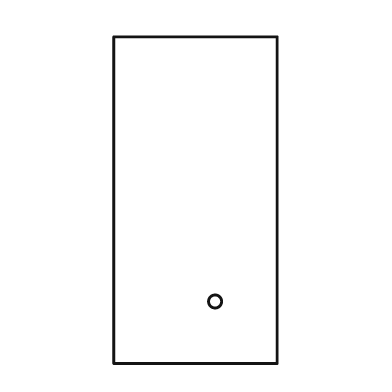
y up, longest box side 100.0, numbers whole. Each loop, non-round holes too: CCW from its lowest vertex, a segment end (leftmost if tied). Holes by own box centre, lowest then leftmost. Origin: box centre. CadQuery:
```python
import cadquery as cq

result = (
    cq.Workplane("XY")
    .moveTo(-25.0, -50.0)
    .lineTo(25.0, -50.0)
    .lineTo(25.0, 50.0)
    .lineTo(-25.0, 50.0)
    .close()
    .moveTo(6.0, -31.0)
    .circle(2.0)
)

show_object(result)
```